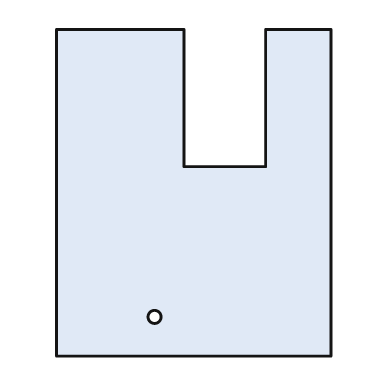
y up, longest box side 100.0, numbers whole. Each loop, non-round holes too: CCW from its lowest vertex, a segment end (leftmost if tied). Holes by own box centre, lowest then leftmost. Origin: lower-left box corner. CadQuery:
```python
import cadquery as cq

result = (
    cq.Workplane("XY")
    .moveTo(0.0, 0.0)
    .lineTo(84.0, 0.0)
    .lineTo(84.0, 100.0)
    .lineTo(64.0, 100.0)
    .lineTo(64.0, 58.0)
    .lineTo(39.0, 58.0)
    .lineTo(39.0, 100.0)
    .lineTo(0.0, 100.0)
    .close()
    .moveTo(30.0, 12.0)
    .circle(2.0)
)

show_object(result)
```